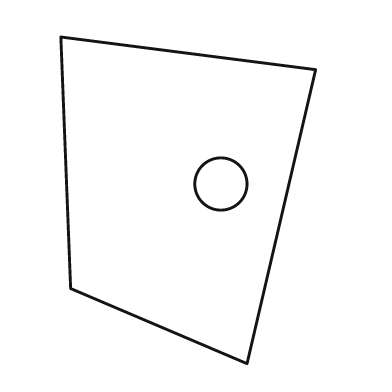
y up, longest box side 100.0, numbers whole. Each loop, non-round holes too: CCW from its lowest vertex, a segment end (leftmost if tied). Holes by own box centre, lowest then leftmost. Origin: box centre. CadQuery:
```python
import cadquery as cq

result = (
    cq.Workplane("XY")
    .moveTo(18.0, -50.0)
    .lineTo(39.0, 40.0)
    .lineTo(-39.0, 50.0)
    .lineTo(-36.0, -27.0)
    .close()
    .moveTo(10.0, 5.0)
    .circle(8.0)
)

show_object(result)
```